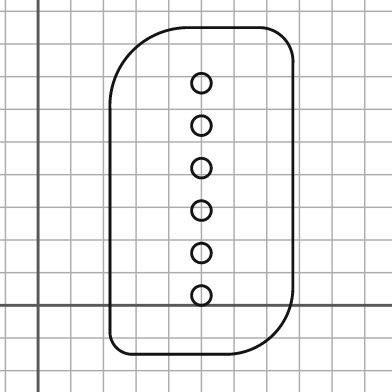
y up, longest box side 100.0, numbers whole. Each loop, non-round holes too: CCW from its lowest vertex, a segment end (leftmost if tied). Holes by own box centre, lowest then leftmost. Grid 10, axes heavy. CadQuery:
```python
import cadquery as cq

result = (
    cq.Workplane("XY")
    .moveTo(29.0, -15.0)
    .lineTo(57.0, -15.0)
    .threePointArc((72.0, -9.0), (78.0, 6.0))
    .lineTo(78.0, 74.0)
    .threePointArc((75.0, 82.0), (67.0, 85.0))
    .lineTo(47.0, 85.0)
    .threePointArc((29.0, 78.0), (22.0, 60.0))
    .lineTo(22.0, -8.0)
    .threePointArc((24.0, -13.0), (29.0, -15.0))
    .close()
    .moveTo(50.0, 3.0)
    .circle(3.0)
    .moveTo(50.0, 16.0)
    .circle(3.0)
    .moveTo(50.0, 29.0)
    .circle(3.0)
    .moveTo(50.0, 42.0)
    .circle(3.0)
    .moveTo(50.0, 55.0)
    .circle(3.0)
    .moveTo(50.0, 68.0)
    .circle(3.0)
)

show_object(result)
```